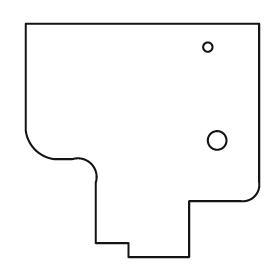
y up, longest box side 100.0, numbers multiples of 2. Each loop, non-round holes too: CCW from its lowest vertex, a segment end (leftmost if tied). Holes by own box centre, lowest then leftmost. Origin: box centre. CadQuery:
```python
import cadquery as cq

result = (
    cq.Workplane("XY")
    .moveTo(-6.0, -50.0)
    .lineTo(20.0, -50.0)
    .lineTo(20.0, -26.0)
    .lineTo(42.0, -26.0)
    .threePointArc((48.0, -24.0), (50.0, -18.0))
    .lineTo(50.0, 50.0)
    .lineTo(-50.0, 50.0)
    .lineTo(-50.0, 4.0)
    .threePointArc((-46.0, -4.0), (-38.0, -8.0))
    .lineTo(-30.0, -8.0)
    .threePointArc((-22.0, -10.0), (-20.0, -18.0))
    .lineTo(-20.0, -44.0)
    .lineTo(-6.0, -44.0)
    .close()
    .moveTo(32.0, 0.0)
    .circle(4.0)
    .moveTo(28.0, 40.0)
    .circle(2.0)
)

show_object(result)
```